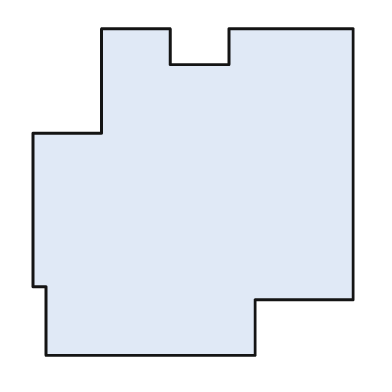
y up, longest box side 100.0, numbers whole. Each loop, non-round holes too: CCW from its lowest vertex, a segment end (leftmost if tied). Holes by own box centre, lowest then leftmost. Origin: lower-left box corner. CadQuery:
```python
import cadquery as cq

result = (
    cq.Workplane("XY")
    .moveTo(4.0, 0.0)
    .lineTo(68.0, 0.0)
    .lineTo(68.0, 17.0)
    .lineTo(98.0, 17.0)
    .lineTo(98.0, 100.0)
    .lineTo(60.0, 100.0)
    .lineTo(60.0, 89.0)
    .lineTo(42.0, 89.0)
    .lineTo(42.0, 100.0)
    .lineTo(21.0, 100.0)
    .lineTo(21.0, 68.0)
    .lineTo(0.0, 68.0)
    .lineTo(0.0, 21.0)
    .lineTo(4.0, 21.0)
    .close()
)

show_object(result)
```